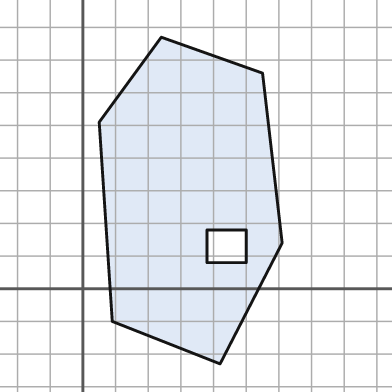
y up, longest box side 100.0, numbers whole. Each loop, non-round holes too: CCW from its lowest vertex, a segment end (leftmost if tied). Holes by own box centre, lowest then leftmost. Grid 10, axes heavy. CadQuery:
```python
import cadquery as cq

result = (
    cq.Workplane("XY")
    .moveTo(42.0, -23.0)
    .lineTo(61.0, 14.0)
    .lineTo(55.0, 66.0)
    .lineTo(24.0, 77.0)
    .lineTo(5.0, 51.0)
    .lineTo(9.0, -10.0)
    .close()
    .moveTo(38.0, 8.0)
    .lineTo(50.0, 8.0)
    .lineTo(50.0, 18.0)
    .lineTo(38.0, 18.0)
    .close()
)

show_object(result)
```